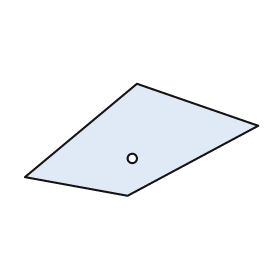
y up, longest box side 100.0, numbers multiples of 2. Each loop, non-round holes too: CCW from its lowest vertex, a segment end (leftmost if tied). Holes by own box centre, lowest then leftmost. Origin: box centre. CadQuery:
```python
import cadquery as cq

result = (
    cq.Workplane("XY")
    .moveTo(-6.0, -24.0)
    .lineTo(50.0, 6.0)
    .lineTo(-2.0, 24.0)
    .lineTo(-50.0, -16.0)
    .close()
    .moveTo(-4.0, -8.0)
    .circle(2.0)
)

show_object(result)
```